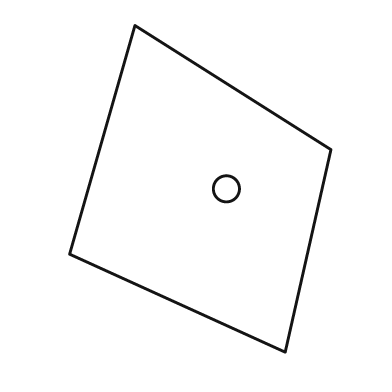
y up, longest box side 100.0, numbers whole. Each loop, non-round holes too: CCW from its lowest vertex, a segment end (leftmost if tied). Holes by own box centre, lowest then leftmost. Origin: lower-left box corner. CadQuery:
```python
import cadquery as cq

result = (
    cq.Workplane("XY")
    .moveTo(66.0, 0.0)
    .lineTo(80.0, 62.0)
    .lineTo(20.0, 100.0)
    .lineTo(0.0, 30.0)
    .close()
    .moveTo(48.0, 50.0)
    .circle(4.0)
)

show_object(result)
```